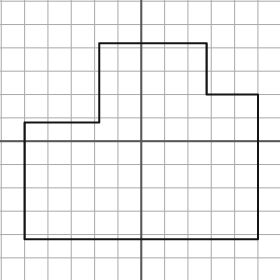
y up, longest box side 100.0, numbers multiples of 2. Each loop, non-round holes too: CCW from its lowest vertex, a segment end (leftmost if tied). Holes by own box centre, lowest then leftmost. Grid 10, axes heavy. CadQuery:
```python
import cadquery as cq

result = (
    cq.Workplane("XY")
    .moveTo(-50.0, -42.0)
    .lineTo(50.0, -42.0)
    .lineTo(50.0, 20.0)
    .lineTo(28.0, 20.0)
    .lineTo(28.0, 42.0)
    .lineTo(-18.0, 42.0)
    .lineTo(-18.0, 8.0)
    .lineTo(-50.0, 8.0)
    .close()
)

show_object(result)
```